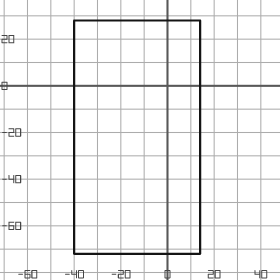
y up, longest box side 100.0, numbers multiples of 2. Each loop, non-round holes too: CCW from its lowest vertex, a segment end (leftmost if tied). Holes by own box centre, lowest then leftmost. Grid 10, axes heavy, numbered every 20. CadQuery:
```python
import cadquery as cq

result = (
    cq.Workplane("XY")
    .moveTo(-40.0, -72.0)
    .lineTo(14.0, -72.0)
    .lineTo(14.0, 28.0)
    .lineTo(-40.0, 28.0)
    .close()
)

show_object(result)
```